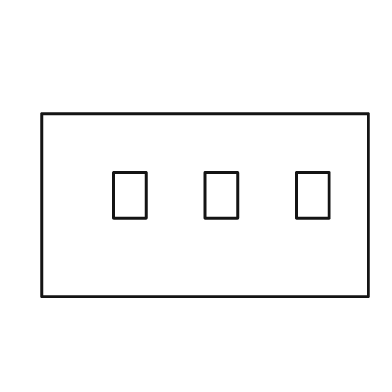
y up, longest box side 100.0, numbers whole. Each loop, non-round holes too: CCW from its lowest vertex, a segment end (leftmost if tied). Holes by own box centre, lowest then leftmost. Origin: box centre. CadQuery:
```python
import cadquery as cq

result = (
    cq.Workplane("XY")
    .moveTo(-50.0, -28.0)
    .lineTo(50.0, -28.0)
    .lineTo(50.0, 28.0)
    .lineTo(-50.0, 28.0)
    .close()
    .moveTo(-28.0, -4.0)
    .lineTo(-18.0, -4.0)
    .lineTo(-18.0, 10.0)
    .lineTo(-28.0, 10.0)
    .close()
    .moveTo(0.0, -4.0)
    .lineTo(10.0, -4.0)
    .lineTo(10.0, 10.0)
    .lineTo(0.0, 10.0)
    .close()
    .moveTo(28.0, -4.0)
    .lineTo(38.0, -4.0)
    .lineTo(38.0, 10.0)
    .lineTo(28.0, 10.0)
    .close()
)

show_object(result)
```